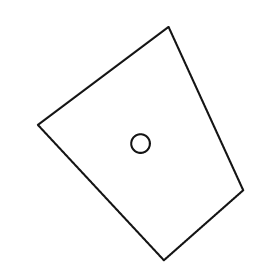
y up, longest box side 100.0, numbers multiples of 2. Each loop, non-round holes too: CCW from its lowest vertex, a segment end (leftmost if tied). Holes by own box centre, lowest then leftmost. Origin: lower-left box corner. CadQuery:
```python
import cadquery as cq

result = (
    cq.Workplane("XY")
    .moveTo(54.0, 0.0)
    .lineTo(88.0, 30.0)
    .lineTo(56.0, 100.0)
    .lineTo(0.0, 58.0)
    .close()
    .moveTo(44.0, 50.0)
    .circle(4.0)
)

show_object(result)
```